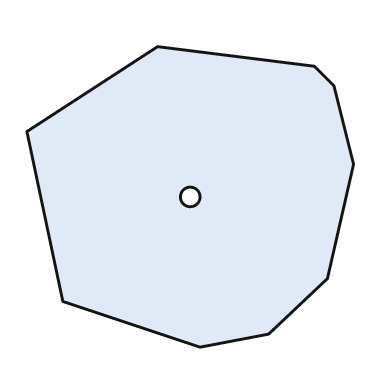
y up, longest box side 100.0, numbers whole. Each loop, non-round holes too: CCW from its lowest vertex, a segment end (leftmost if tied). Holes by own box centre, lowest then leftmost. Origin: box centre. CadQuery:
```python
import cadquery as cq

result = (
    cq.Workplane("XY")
    .moveTo(3.0, -46.0)
    .lineTo(24.0, -42.0)
    .lineTo(42.0, -25.0)
    .lineTo(50.0, 10.0)
    .lineTo(44.0, 34.0)
    .lineTo(38.0, 40.0)
    .lineTo(-10.0, 46.0)
    .lineTo(-50.0, 20.0)
    .lineTo(-39.0, -32.0)
    .close()
    .moveTo(0.0, 0.0)
    .circle(3.0)
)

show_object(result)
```